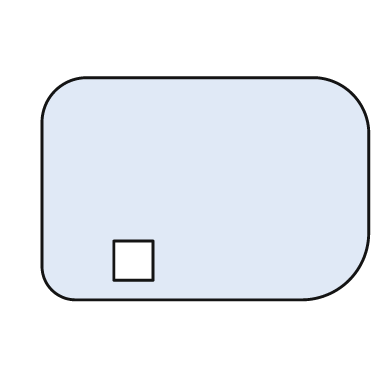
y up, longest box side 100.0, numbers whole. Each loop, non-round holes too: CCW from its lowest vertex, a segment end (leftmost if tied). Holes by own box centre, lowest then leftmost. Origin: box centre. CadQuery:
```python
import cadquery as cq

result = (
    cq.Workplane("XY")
    .moveTo(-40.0, -34.0)
    .lineTo(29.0, -34.0)
    .threePointArc((44.0, -28.0), (50.0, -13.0))
    .lineTo(50.0, 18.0)
    .threePointArc((45.0, 29.0), (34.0, 34.0))
    .lineTo(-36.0, 34.0)
    .threePointArc((-46.0, 30.0), (-50.0, 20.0))
    .lineTo(-50.0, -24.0)
    .threePointArc((-47.0, -31.0), (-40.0, -34.0))
    .close()
    .moveTo(-28.0, -28.0)
    .lineTo(-16.0, -28.0)
    .lineTo(-16.0, -16.0)
    .lineTo(-28.0, -16.0)
    .close()
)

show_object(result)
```